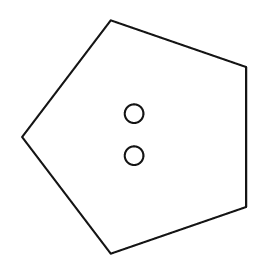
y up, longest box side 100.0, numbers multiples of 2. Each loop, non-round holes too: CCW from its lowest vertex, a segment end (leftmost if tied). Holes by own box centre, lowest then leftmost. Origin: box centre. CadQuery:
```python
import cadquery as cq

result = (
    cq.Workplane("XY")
    .moveTo(-10.0, -50.0)
    .lineTo(48.0, -30.0)
    .lineTo(48.0, 30.0)
    .lineTo(-10.0, 50.0)
    .lineTo(-48.0, 0.0)
    .close()
    .moveTo(0.0, -8.0)
    .circle(4.0)
    .moveTo(0.0, 10.0)
    .circle(4.0)
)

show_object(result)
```